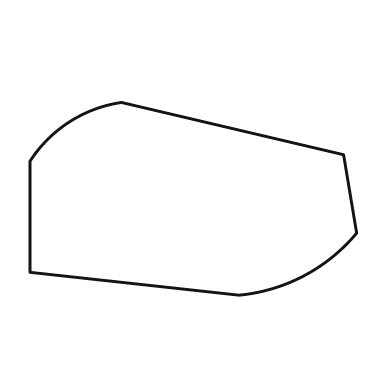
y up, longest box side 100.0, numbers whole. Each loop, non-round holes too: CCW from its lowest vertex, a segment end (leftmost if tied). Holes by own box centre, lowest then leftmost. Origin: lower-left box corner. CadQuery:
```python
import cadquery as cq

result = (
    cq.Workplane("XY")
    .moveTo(64.0, 0.0)
    .threePointArc((84.0, 6.0), (100.0, 19.0))
    .lineTo(96.0, 43.0)
    .lineTo(28.0, 59.0)
    .threePointArc((12.0, 53.0), (0.0, 41.0))
    .lineTo(0.0, 7.0)
    .close()
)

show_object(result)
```